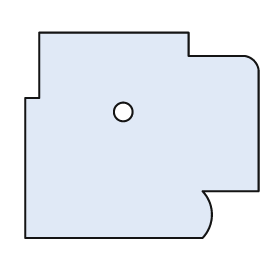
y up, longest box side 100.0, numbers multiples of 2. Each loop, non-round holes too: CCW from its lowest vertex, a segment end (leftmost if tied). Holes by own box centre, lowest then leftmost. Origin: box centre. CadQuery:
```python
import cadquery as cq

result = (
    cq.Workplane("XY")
    .moveTo(-50.0, -44.0)
    .lineTo(26.0, -44.0)
    .threePointArc((30.0, -34.0), (26.0, -24.0))
    .lineTo(50.0, -24.0)
    .lineTo(50.0, 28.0)
    .threePointArc((48.0, 32.0), (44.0, 34.0))
    .lineTo(20.0, 34.0)
    .lineTo(20.0, 44.0)
    .lineTo(-44.0, 44.0)
    .lineTo(-44.0, 16.0)
    .lineTo(-50.0, 16.0)
    .close()
    .moveTo(-8.0, 10.0)
    .circle(4.0)
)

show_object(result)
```